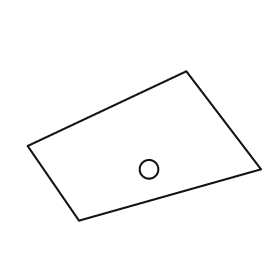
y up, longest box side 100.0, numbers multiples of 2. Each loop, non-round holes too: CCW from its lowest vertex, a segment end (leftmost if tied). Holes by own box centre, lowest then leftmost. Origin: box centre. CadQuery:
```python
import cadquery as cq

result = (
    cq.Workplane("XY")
    .moveTo(-28.0, -32.0)
    .lineTo(50.0, -10.0)
    .lineTo(18.0, 32.0)
    .lineTo(-50.0, 0.0)
    .close()
    .moveTo(2.0, -10.0)
    .circle(4.0)
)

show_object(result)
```